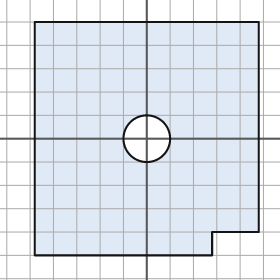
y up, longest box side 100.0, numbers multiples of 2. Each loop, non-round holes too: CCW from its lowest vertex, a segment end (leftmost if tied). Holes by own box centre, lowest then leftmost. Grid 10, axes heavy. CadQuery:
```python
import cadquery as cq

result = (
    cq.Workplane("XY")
    .moveTo(-48.0, -50.0)
    .lineTo(28.0, -50.0)
    .lineTo(28.0, -40.0)
    .lineTo(48.0, -40.0)
    .lineTo(48.0, 50.0)
    .lineTo(-48.0, 50.0)
    .close()
    .moveTo(0.0, 0.0)
    .circle(10.0)
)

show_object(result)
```